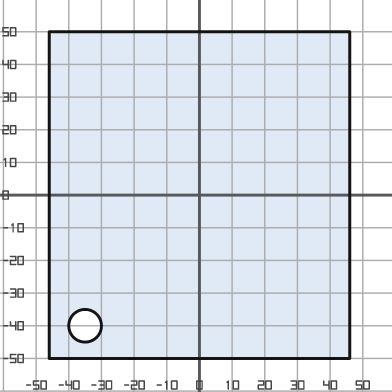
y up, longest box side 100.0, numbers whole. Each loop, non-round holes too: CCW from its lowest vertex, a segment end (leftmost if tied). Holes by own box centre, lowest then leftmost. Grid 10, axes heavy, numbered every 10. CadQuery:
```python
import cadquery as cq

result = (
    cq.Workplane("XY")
    .moveTo(-46.0, -50.0)
    .lineTo(46.0, -50.0)
    .lineTo(46.0, 50.0)
    .lineTo(-46.0, 50.0)
    .close()
    .moveTo(-35.0, -40.0)
    .circle(5.0)
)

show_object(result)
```